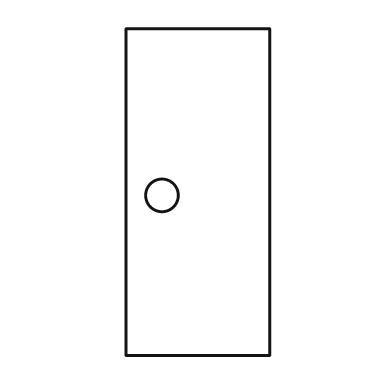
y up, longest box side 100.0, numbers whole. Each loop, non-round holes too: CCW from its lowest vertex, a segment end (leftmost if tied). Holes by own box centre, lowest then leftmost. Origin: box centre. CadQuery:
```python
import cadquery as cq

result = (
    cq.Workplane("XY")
    .moveTo(-22.0, -50.0)
    .lineTo(22.0, -50.0)
    .lineTo(22.0, 50.0)
    .lineTo(-22.0, 50.0)
    .close()
    .moveTo(-11.0, -1.0)
    .circle(5.0)
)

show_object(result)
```